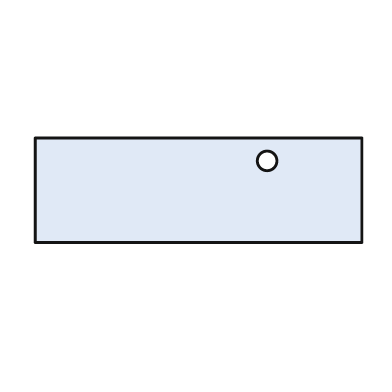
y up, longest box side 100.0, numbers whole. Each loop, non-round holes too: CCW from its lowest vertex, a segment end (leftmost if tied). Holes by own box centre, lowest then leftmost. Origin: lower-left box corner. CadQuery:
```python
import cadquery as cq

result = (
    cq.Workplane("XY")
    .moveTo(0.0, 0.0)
    .lineTo(100.0, 0.0)
    .lineTo(100.0, 32.0)
    .lineTo(0.0, 32.0)
    .close()
    .moveTo(71.0, 25.0)
    .circle(3.0)
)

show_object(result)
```